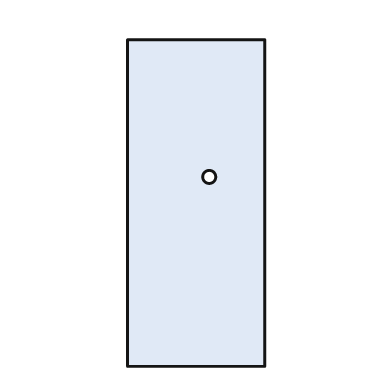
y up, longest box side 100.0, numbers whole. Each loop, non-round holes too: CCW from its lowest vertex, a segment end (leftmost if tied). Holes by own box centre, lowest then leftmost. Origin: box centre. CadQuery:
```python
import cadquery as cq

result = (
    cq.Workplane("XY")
    .moveTo(-21.0, -50.0)
    .lineTo(21.0, -50.0)
    .lineTo(21.0, 50.0)
    .lineTo(-21.0, 50.0)
    .close()
    .moveTo(4.0, 8.0)
    .circle(2.0)
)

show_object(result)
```